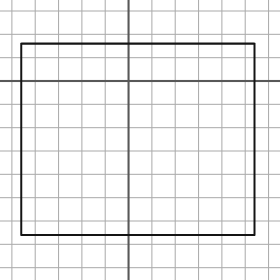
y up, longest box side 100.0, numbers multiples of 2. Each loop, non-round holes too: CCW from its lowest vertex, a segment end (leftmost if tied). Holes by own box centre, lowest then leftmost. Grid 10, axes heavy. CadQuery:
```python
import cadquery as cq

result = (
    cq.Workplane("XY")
    .moveTo(-46.0, -66.0)
    .lineTo(54.0, -66.0)
    .lineTo(54.0, 16.0)
    .lineTo(-46.0, 16.0)
    .close()
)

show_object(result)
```